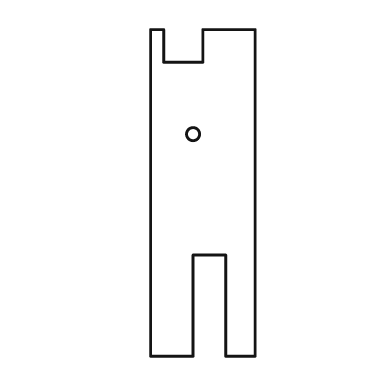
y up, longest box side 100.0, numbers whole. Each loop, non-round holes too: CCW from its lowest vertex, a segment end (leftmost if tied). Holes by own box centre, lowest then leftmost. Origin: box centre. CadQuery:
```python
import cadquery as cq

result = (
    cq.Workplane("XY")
    .moveTo(-16.0, -50.0)
    .lineTo(-3.0, -50.0)
    .lineTo(-3.0, -19.0)
    .lineTo(7.0, -19.0)
    .lineTo(7.0, -50.0)
    .lineTo(16.0, -50.0)
    .lineTo(16.0, 50.0)
    .lineTo(0.0, 50.0)
    .lineTo(0.0, 40.0)
    .lineTo(-12.0, 40.0)
    .lineTo(-12.0, 50.0)
    .lineTo(-16.0, 50.0)
    .close()
    .moveTo(-3.0, 18.0)
    .circle(2.0)
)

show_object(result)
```